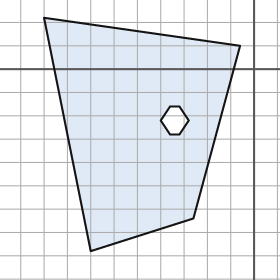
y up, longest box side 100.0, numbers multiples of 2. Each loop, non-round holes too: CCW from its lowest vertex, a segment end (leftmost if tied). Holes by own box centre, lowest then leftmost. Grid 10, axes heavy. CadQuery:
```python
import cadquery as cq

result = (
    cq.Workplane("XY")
    .moveTo(-70.0, -78.0)
    .lineTo(-26.0, -64.0)
    .lineTo(-6.0, 10.0)
    .lineTo(-90.0, 22.0)
    .close()
    .moveTo(-36.0, -28.0)
    .lineTo(-32.0, -28.0)
    .lineTo(-28.0, -22.0)
    .lineTo(-32.0, -16.0)
    .lineTo(-36.0, -16.0)
    .lineTo(-40.0, -22.0)
    .close()
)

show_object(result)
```